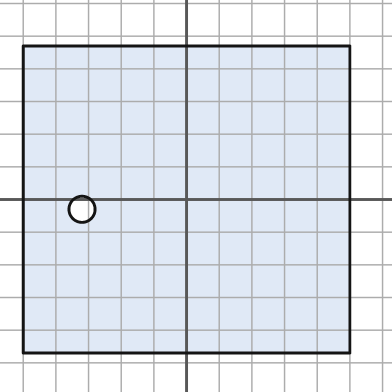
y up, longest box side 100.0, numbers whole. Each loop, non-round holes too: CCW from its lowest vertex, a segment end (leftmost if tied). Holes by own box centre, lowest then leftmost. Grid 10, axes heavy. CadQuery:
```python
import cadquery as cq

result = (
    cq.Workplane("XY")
    .moveTo(-50.0, -47.0)
    .lineTo(50.0, -47.0)
    .lineTo(50.0, 47.0)
    .lineTo(-50.0, 47.0)
    .close()
    .moveTo(-32.0, -3.0)
    .circle(4.0)
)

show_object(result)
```